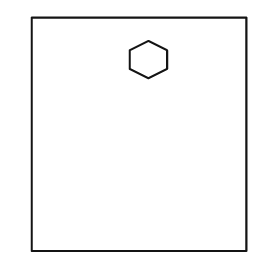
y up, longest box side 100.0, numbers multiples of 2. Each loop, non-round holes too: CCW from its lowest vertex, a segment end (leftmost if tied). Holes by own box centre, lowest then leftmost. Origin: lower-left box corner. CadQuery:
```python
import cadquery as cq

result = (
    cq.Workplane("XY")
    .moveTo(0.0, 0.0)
    .lineTo(92.0, 0.0)
    .lineTo(92.0, 100.0)
    .lineTo(0.0, 100.0)
    .close()
    .moveTo(50.0, 74.0)
    .lineTo(58.0, 78.0)
    .lineTo(58.0, 86.0)
    .lineTo(50.0, 90.0)
    .lineTo(42.0, 86.0)
    .lineTo(42.0, 78.0)
    .close()
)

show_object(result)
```